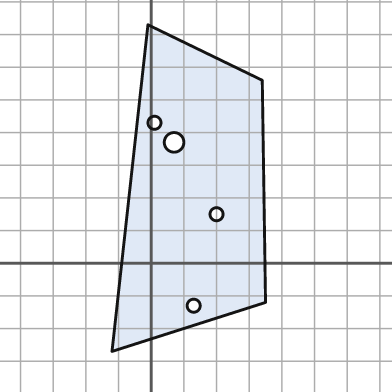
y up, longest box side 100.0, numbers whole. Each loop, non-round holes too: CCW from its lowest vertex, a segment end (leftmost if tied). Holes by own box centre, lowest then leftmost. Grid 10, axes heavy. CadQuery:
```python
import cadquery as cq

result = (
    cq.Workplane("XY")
    .moveTo(-12.0, -27.0)
    .lineTo(35.0, -12.0)
    .lineTo(34.0, 56.0)
    .lineTo(-1.0, 73.0)
    .close()
    .moveTo(13.0, -13.0)
    .circle(2.0)
    .moveTo(20.0, 15.0)
    .circle(2.0)
    .moveTo(7.0, 37.0)
    .circle(3.0)
    .moveTo(1.0, 43.0)
    .circle(2.0)
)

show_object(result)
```